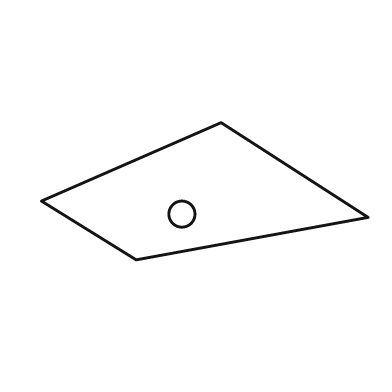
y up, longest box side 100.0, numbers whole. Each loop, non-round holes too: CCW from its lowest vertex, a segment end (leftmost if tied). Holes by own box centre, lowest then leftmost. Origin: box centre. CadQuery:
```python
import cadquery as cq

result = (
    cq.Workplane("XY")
    .moveTo(-21.0, -21.0)
    .lineTo(50.0, -8.0)
    .lineTo(5.0, 21.0)
    .lineTo(-50.0, -3.0)
    .close()
    .moveTo(-7.0, -7.0)
    .circle(4.0)
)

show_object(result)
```